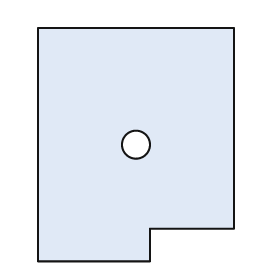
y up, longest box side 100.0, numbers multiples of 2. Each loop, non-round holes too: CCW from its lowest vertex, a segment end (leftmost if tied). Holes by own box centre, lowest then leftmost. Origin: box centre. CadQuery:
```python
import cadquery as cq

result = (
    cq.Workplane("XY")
    .moveTo(-42.0, -50.0)
    .lineTo(6.0, -50.0)
    .lineTo(6.0, -36.0)
    .lineTo(42.0, -36.0)
    .lineTo(42.0, 50.0)
    .lineTo(-42.0, 50.0)
    .close()
    .moveTo(0.0, 0.0)
    .circle(6.0)
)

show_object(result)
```